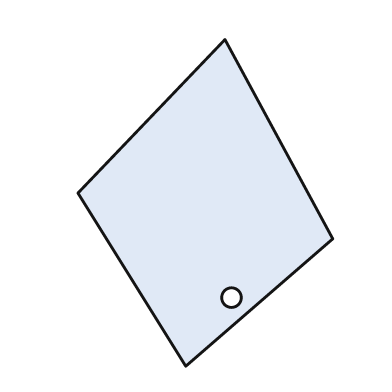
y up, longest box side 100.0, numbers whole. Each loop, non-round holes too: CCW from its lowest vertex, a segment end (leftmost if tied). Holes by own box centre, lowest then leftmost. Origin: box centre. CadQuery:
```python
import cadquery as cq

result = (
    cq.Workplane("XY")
    .moveTo(-6.0, -50.0)
    .lineTo(39.0, -11.0)
    .lineTo(6.0, 50.0)
    .lineTo(-39.0, 3.0)
    .close()
    .moveTo(8.0, -29.0)
    .circle(3.0)
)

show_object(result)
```